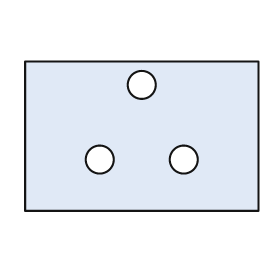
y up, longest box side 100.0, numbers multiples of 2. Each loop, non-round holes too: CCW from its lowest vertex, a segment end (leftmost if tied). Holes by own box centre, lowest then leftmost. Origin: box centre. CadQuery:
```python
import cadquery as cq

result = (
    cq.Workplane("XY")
    .moveTo(-50.0, -32.0)
    .lineTo(50.0, -32.0)
    .lineTo(50.0, 32.0)
    .lineTo(-50.0, 32.0)
    .close()
    .moveTo(-18.0, -10.0)
    .circle(6.0)
    .moveTo(18.0, -10.0)
    .circle(6.0)
    .moveTo(0.0, 22.0)
    .circle(6.0)
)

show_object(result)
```